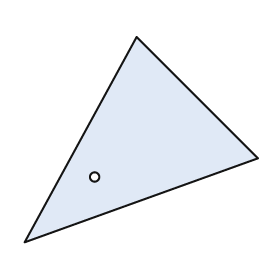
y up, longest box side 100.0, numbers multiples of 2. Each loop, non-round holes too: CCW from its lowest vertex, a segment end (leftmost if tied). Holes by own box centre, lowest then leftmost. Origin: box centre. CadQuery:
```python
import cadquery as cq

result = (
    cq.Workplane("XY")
    .moveTo(-50.0, -44.0)
    .lineTo(50.0, -8.0)
    .lineTo(-2.0, 44.0)
    .close()
    .moveTo(-20.0, -16.0)
    .circle(2.0)
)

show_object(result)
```